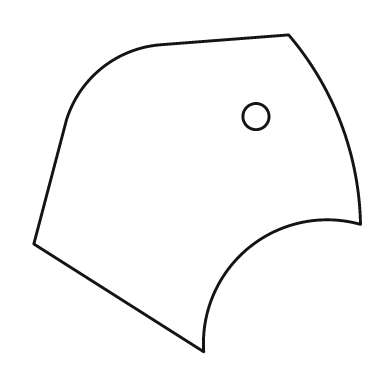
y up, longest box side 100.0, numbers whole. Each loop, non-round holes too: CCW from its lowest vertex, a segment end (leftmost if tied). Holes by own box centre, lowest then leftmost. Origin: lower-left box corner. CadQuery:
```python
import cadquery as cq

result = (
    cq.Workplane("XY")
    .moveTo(52.0, 0.0)
    .threePointArc((66.0, 32.0), (100.0, 39.0))
    .threePointArc((94.0, 70.0), (78.0, 97.0))
    .lineTo(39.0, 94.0)
    .threePointArc((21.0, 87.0), (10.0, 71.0))
    .lineTo(0.0, 33.0)
    .close()
    .moveTo(68.0, 72.0)
    .circle(4.0)
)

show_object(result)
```